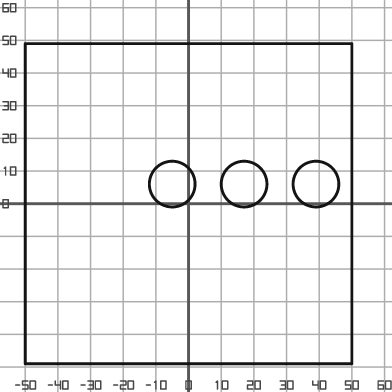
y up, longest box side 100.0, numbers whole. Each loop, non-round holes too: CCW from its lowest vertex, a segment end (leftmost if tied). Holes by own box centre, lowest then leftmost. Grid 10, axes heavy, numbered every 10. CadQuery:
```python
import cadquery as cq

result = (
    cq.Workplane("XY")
    .moveTo(-50.0, -49.0)
    .lineTo(50.0, -49.0)
    .lineTo(50.0, 49.0)
    .lineTo(-50.0, 49.0)
    .close()
    .moveTo(-5.0, 6.0)
    .circle(7.0)
    .moveTo(17.0, 6.0)
    .circle(7.0)
    .moveTo(39.0, 6.0)
    .circle(7.0)
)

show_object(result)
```